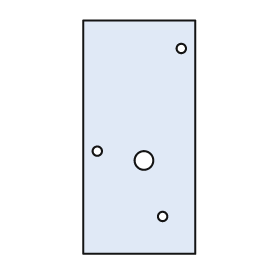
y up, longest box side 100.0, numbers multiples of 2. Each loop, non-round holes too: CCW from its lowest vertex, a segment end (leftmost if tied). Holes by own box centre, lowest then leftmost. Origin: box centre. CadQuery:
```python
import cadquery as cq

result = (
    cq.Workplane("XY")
    .moveTo(-24.0, -50.0)
    .lineTo(24.0, -50.0)
    .lineTo(24.0, 50.0)
    .lineTo(-24.0, 50.0)
    .close()
    .moveTo(10.0, -34.0)
    .circle(2.0)
    .moveTo(2.0, -10.0)
    .circle(4.0)
    .moveTo(-18.0, -6.0)
    .circle(2.0)
    .moveTo(18.0, 38.0)
    .circle(2.0)
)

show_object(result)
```